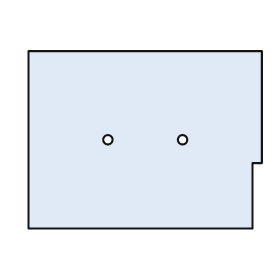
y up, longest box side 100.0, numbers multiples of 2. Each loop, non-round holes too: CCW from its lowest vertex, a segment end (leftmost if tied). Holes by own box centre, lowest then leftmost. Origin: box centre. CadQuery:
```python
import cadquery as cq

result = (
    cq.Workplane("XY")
    .moveTo(-50.0, -38.0)
    .lineTo(46.0, -38.0)
    .lineTo(46.0, -10.0)
    .lineTo(50.0, -10.0)
    .lineTo(50.0, 38.0)
    .lineTo(-50.0, 38.0)
    .close()
    .moveTo(-16.0, 0.0)
    .circle(2.0)
    .moveTo(16.0, 0.0)
    .circle(2.0)
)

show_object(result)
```